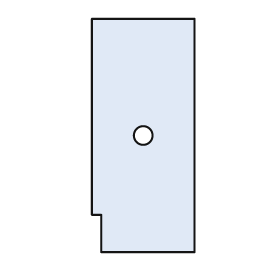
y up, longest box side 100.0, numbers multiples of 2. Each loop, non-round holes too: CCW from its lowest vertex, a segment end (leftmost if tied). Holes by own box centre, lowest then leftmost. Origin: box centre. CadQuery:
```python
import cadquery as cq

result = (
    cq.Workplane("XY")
    .moveTo(-18.0, -50.0)
    .lineTo(22.0, -50.0)
    .lineTo(22.0, 50.0)
    .lineTo(-22.0, 50.0)
    .lineTo(-22.0, -34.0)
    .lineTo(-18.0, -34.0)
    .close()
    .moveTo(0.0, 0.0)
    .circle(4.0)
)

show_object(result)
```